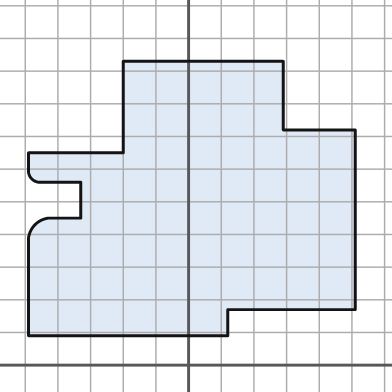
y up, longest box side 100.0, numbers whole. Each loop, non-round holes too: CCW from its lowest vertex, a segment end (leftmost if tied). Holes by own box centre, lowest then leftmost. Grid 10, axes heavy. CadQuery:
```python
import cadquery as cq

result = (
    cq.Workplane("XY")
    .moveTo(-49.0, 9.0)
    .lineTo(12.0, 9.0)
    .lineTo(12.0, 17.0)
    .lineTo(51.0, 17.0)
    .lineTo(51.0, 72.0)
    .lineTo(29.0, 72.0)
    .lineTo(29.0, 93.0)
    .lineTo(-20.0, 93.0)
    .lineTo(-20.0, 65.0)
    .lineTo(-49.0, 65.0)
    .lineTo(-49.0, 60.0)
    .threePointArc((-48.0, 57.0), (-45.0, 56.0))
    .lineTo(-33.0, 56.0)
    .lineTo(-33.0, 45.0)
    .lineTo(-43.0, 45.0)
    .threePointArc((-47.0, 43.0), (-49.0, 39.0))
    .close()
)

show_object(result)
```